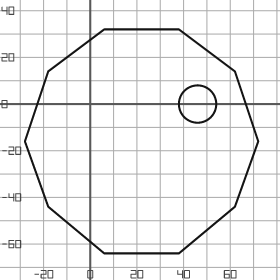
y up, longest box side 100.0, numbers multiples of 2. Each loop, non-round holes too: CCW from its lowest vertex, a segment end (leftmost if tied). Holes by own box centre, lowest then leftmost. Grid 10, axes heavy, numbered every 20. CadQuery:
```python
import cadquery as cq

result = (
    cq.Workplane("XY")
    .moveTo(6.0, -64.0)
    .lineTo(38.0, -64.0)
    .lineTo(62.0, -44.0)
    .lineTo(72.0, -16.0)
    .lineTo(62.0, 14.0)
    .lineTo(38.0, 32.0)
    .lineTo(6.0, 32.0)
    .lineTo(-18.0, 14.0)
    .lineTo(-28.0, -16.0)
    .lineTo(-18.0, -44.0)
    .close()
    .moveTo(46.0, 0.0)
    .circle(8.0)
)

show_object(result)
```